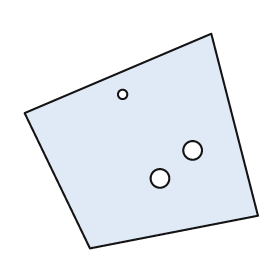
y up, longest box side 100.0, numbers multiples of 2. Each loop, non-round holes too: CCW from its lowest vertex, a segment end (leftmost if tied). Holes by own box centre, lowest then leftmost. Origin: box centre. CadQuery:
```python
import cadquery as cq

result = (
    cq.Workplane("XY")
    .moveTo(-22.0, -46.0)
    .lineTo(50.0, -32.0)
    .lineTo(30.0, 46.0)
    .lineTo(-50.0, 12.0)
    .close()
    .moveTo(8.0, -16.0)
    .circle(4.0)
    .moveTo(22.0, -4.0)
    .circle(4.0)
    .moveTo(-8.0, 20.0)
    .circle(2.0)
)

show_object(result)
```